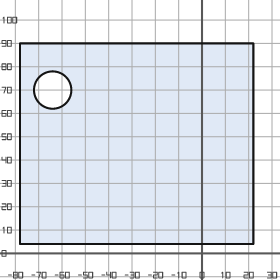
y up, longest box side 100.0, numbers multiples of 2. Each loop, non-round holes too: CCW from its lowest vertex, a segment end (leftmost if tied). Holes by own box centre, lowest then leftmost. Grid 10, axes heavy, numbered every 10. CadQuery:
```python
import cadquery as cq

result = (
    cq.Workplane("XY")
    .moveTo(-78.0, 4.0)
    .lineTo(22.0, 4.0)
    .lineTo(22.0, 90.0)
    .lineTo(-78.0, 90.0)
    .close()
    .moveTo(-64.0, 70.0)
    .circle(8.0)
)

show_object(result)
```